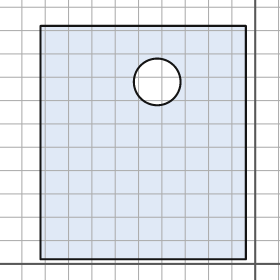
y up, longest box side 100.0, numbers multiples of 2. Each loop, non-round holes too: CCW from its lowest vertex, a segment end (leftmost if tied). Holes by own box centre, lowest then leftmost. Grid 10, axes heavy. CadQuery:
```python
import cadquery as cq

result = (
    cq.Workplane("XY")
    .moveTo(-92.0, 2.0)
    .lineTo(-4.0, 2.0)
    .lineTo(-4.0, 102.0)
    .lineTo(-92.0, 102.0)
    .close()
    .moveTo(-42.0, 78.0)
    .circle(10.0)
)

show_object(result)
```